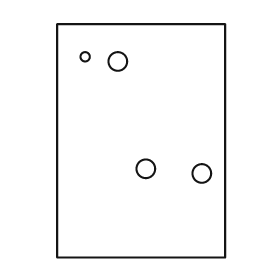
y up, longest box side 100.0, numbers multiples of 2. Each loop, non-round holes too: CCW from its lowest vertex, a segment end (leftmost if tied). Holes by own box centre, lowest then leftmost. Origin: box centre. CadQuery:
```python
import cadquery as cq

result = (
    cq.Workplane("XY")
    .moveTo(-36.0, -50.0)
    .lineTo(36.0, -50.0)
    .lineTo(36.0, 50.0)
    .lineTo(-36.0, 50.0)
    .close()
    .moveTo(26.0, -14.0)
    .circle(4.0)
    .moveTo(2.0, -12.0)
    .circle(4.0)
    .moveTo(-10.0, 34.0)
    .circle(4.0)
    .moveTo(-24.0, 36.0)
    .circle(2.0)
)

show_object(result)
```